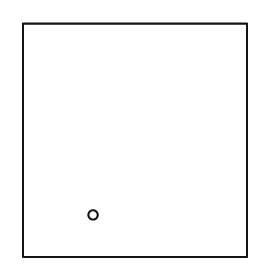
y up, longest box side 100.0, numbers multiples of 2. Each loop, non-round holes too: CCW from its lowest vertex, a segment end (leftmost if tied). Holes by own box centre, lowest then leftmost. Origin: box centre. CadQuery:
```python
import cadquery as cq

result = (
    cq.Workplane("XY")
    .moveTo(-48.0, -50.0)
    .lineTo(48.0, -50.0)
    .lineTo(48.0, 50.0)
    .lineTo(-48.0, 50.0)
    .close()
    .moveTo(-18.0, -32.0)
    .circle(2.0)
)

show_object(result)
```